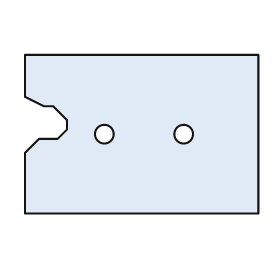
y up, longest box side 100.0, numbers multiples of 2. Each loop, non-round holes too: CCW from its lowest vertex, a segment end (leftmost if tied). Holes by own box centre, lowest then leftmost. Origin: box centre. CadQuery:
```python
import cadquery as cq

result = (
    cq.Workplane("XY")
    .moveTo(-50.0, -34.0)
    .lineTo(50.0, -34.0)
    .lineTo(50.0, 34.0)
    .lineTo(-50.0, 34.0)
    .lineTo(-50.0, 16.0)
    .lineTo(-42.0, 12.0)
    .lineTo(-38.0, 12.0)
    .lineTo(-32.0, 6.0)
    .lineTo(-32.0, 2.0)
    .lineTo(-36.0, -2.0)
    .lineTo(-44.0, -2.0)
    .lineTo(-50.0, -8.0)
    .close()
    .moveTo(-16.0, 0.0)
    .circle(4.0)
    .moveTo(18.0, 0.0)
    .circle(4.0)
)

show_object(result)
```